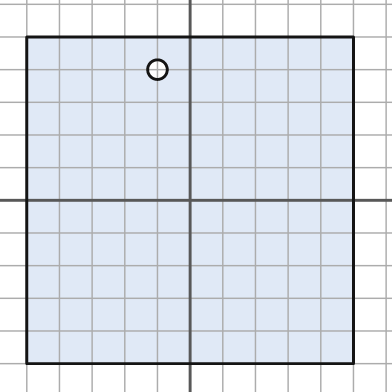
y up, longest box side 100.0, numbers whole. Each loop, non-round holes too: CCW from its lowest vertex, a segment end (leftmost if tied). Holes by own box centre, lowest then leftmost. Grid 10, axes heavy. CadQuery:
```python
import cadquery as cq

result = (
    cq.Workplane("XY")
    .moveTo(-50.0, -50.0)
    .lineTo(50.0, -50.0)
    .lineTo(50.0, 50.0)
    .lineTo(-50.0, 50.0)
    .close()
    .moveTo(-10.0, 40.0)
    .circle(3.0)
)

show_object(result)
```